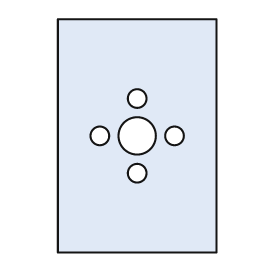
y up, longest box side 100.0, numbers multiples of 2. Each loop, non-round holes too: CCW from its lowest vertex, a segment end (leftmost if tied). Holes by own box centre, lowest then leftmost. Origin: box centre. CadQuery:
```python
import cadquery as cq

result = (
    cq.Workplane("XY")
    .moveTo(-34.0, -50.0)
    .lineTo(34.0, -50.0)
    .lineTo(34.0, 50.0)
    .lineTo(-34.0, 50.0)
    .close()
    .moveTo(0.0, -16.0)
    .circle(4.0)
    .moveTo(-16.0, 0.0)
    .circle(4.0)
    .moveTo(0.0, 0.0)
    .circle(8.0)
    .moveTo(16.0, 0.0)
    .circle(4.0)
    .moveTo(0.0, 16.0)
    .circle(4.0)
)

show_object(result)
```